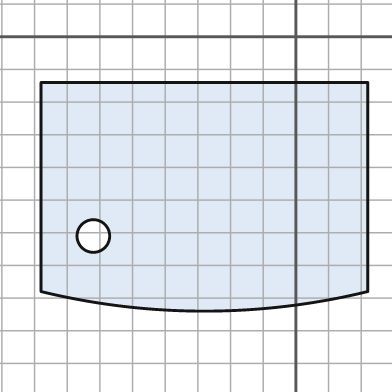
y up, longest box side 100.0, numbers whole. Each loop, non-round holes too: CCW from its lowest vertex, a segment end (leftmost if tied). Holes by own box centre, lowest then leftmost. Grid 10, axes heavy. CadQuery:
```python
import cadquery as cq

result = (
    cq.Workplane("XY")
    .moveTo(-78.0, -78.0)
    .threePointArc((-28.0, -84.0), (22.0, -78.0))
    .lineTo(22.0, -14.0)
    .lineTo(-78.0, -14.0)
    .close()
    .moveTo(-62.0, -61.0)
    .circle(5.0)
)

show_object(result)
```